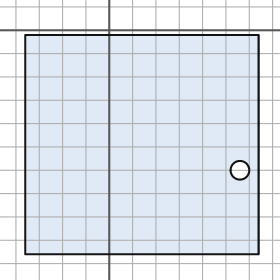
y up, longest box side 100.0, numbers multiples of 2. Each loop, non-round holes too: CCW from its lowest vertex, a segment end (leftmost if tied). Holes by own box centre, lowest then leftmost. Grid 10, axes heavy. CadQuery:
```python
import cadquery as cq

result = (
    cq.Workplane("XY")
    .moveTo(-36.0, -96.0)
    .lineTo(64.0, -96.0)
    .lineTo(64.0, -2.0)
    .lineTo(-36.0, -2.0)
    .close()
    .moveTo(56.0, -60.0)
    .circle(4.0)
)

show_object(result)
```